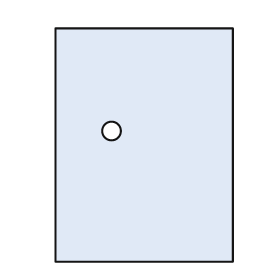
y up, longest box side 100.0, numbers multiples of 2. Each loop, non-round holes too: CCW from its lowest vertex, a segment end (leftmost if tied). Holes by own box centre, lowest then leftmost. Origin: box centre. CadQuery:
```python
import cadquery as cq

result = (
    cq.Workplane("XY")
    .moveTo(-38.0, -50.0)
    .lineTo(38.0, -50.0)
    .lineTo(38.0, 50.0)
    .lineTo(-38.0, 50.0)
    .close()
    .moveTo(-14.0, 6.0)
    .circle(4.0)
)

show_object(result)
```